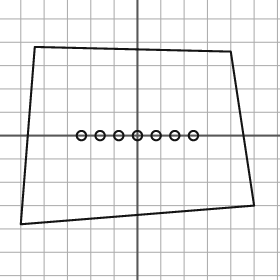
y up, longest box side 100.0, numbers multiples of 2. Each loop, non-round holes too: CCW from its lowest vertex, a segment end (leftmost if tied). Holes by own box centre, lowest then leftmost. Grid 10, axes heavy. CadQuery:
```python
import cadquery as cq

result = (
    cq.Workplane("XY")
    .moveTo(-50.0, -38.0)
    .lineTo(50.0, -30.0)
    .lineTo(40.0, 36.0)
    .lineTo(-44.0, 38.0)
    .close()
    .moveTo(-24.0, 0.0)
    .circle(2.0)
    .moveTo(-16.0, 0.0)
    .circle(2.0)
    .moveTo(-8.0, 0.0)
    .circle(2.0)
    .moveTo(0.0, 0.0)
    .circle(2.0)
    .moveTo(8.0, 0.0)
    .circle(2.0)
    .moveTo(16.0, 0.0)
    .circle(2.0)
    .moveTo(24.0, 0.0)
    .circle(2.0)
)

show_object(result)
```